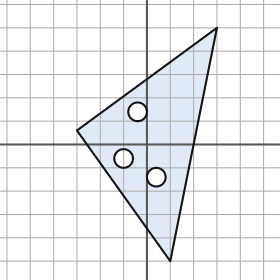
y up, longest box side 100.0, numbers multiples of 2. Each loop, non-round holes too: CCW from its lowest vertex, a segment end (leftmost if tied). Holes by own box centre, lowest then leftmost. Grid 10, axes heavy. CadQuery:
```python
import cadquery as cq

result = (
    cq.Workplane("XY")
    .moveTo(10.0, -50.0)
    .lineTo(30.0, 50.0)
    .lineTo(-30.0, 6.0)
    .close()
    .moveTo(4.0, -14.0)
    .circle(4.0)
    .moveTo(-10.0, -6.0)
    .circle(4.0)
    .moveTo(-4.0, 14.0)
    .circle(4.0)
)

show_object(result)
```